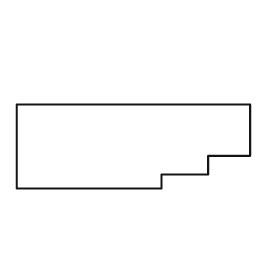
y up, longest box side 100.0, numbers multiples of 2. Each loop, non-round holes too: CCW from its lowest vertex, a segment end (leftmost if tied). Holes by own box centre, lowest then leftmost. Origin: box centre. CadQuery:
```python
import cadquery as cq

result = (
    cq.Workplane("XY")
    .moveTo(-50.0, -18.0)
    .lineTo(12.0, -18.0)
    .lineTo(12.0, -12.0)
    .lineTo(32.0, -12.0)
    .lineTo(32.0, -4.0)
    .lineTo(50.0, -4.0)
    .lineTo(50.0, 18.0)
    .lineTo(-50.0, 18.0)
    .close()
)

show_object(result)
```